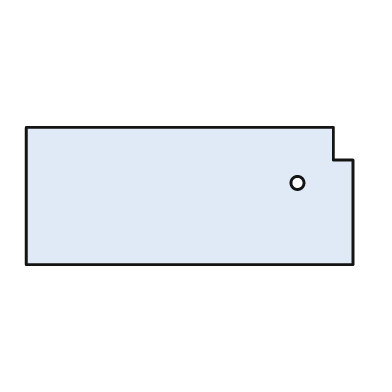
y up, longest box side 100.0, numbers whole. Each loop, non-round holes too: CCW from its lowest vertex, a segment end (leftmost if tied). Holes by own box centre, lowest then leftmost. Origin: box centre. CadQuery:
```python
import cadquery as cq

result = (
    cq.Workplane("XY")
    .moveTo(-50.0, -21.0)
    .lineTo(50.0, -21.0)
    .lineTo(50.0, 11.0)
    .lineTo(44.0, 11.0)
    .lineTo(44.0, 21.0)
    .lineTo(-50.0, 21.0)
    .close()
    .moveTo(33.0, 4.0)
    .circle(2.0)
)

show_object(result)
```